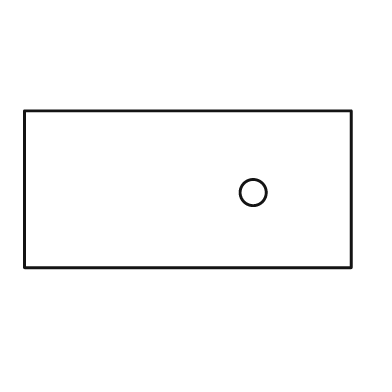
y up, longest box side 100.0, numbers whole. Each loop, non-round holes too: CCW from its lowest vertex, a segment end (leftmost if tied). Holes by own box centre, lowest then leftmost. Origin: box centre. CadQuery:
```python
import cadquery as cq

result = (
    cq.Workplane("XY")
    .moveTo(-50.0, -24.0)
    .lineTo(50.0, -24.0)
    .lineTo(50.0, 24.0)
    .lineTo(-50.0, 24.0)
    .close()
    .moveTo(20.0, -1.0)
    .circle(4.0)
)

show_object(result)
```